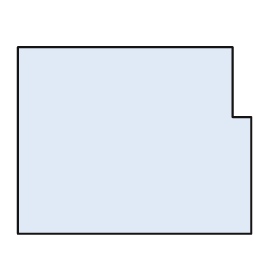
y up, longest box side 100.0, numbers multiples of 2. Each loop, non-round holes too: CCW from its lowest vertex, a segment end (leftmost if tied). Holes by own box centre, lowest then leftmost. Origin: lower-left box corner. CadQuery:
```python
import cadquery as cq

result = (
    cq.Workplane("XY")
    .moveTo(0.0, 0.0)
    .lineTo(100.0, 0.0)
    .lineTo(100.0, 50.0)
    .lineTo(92.0, 50.0)
    .lineTo(92.0, 80.0)
    .lineTo(0.0, 80.0)
    .close()
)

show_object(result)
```